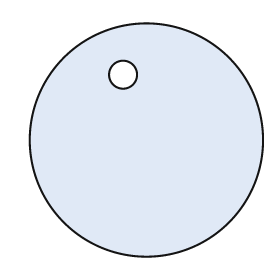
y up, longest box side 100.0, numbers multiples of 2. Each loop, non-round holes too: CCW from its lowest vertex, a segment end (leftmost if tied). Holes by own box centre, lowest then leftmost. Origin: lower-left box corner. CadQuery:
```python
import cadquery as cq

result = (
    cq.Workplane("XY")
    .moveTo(50.0, 50.0)
    .circle(50.0)
    .moveTo(40.0, 78.0)
    .circle(6.0)
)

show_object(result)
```